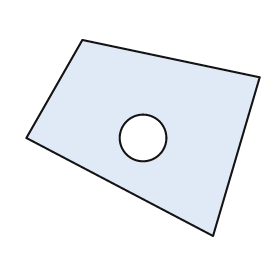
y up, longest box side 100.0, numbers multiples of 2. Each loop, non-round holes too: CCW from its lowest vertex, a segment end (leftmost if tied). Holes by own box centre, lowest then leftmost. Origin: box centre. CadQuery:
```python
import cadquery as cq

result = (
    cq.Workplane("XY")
    .moveTo(30.0, -42.0)
    .lineTo(50.0, 26.0)
    .lineTo(-26.0, 42.0)
    .lineTo(-50.0, 0.0)
    .close()
    .moveTo(0.0, 0.0)
    .circle(10.0)
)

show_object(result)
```